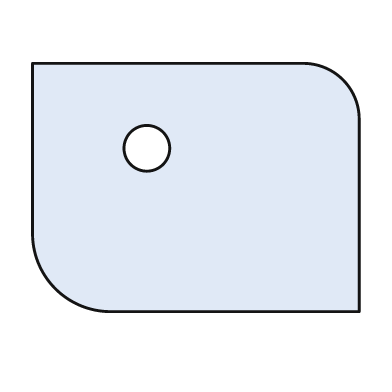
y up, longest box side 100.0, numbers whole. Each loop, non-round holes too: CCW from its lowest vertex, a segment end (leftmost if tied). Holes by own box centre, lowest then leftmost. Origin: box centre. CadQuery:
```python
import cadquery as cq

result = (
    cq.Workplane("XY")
    .moveTo(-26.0, -38.0)
    .lineTo(50.0, -38.0)
    .lineTo(50.0, 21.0)
    .threePointArc((45.0, 33.0), (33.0, 38.0))
    .lineTo(-50.0, 38.0)
    .lineTo(-50.0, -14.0)
    .threePointArc((-43.0, -31.0), (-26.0, -38.0))
    .close()
    .moveTo(-15.0, 12.0)
    .circle(7.0)
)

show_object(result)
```